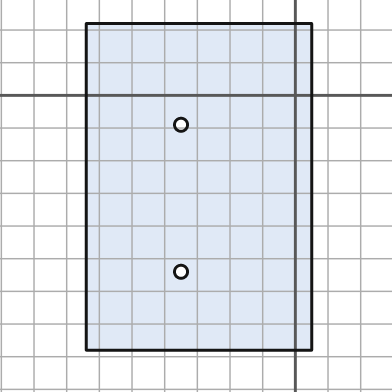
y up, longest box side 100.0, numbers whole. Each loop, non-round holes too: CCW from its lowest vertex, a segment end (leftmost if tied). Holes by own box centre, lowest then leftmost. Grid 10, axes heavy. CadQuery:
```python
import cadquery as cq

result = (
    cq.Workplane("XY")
    .moveTo(-64.0, -78.0)
    .lineTo(5.0, -78.0)
    .lineTo(5.0, 22.0)
    .lineTo(-64.0, 22.0)
    .close()
    .moveTo(-35.0, -54.0)
    .circle(2.0)
    .moveTo(-35.0, -9.0)
    .circle(2.0)
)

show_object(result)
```